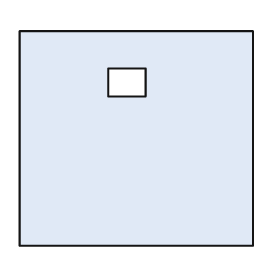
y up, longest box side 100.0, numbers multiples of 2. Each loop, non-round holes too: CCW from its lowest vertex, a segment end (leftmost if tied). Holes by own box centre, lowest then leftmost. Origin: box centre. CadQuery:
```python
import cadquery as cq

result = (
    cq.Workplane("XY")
    .moveTo(-50.0, -46.0)
    .lineTo(50.0, -46.0)
    .lineTo(50.0, 46.0)
    .lineTo(-50.0, 46.0)
    .close()
    .moveTo(-12.0, 18.0)
    .lineTo(4.0, 18.0)
    .lineTo(4.0, 30.0)
    .lineTo(-12.0, 30.0)
    .close()
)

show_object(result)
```